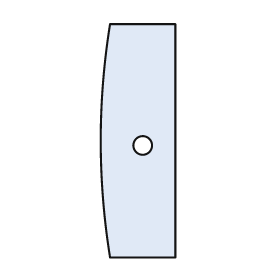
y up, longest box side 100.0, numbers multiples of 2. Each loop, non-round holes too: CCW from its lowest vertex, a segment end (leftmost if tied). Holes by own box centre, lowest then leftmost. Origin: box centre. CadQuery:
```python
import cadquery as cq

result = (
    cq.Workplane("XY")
    .moveTo(-12.0, -50.0)
    .lineTo(16.0, -50.0)
    .lineTo(16.0, 50.0)
    .lineTo(-12.0, 50.0)
    .threePointArc((-16.0, 0.0), (-12.0, -50.0))
    .close()
    .moveTo(2.0, -2.0)
    .circle(4.0)
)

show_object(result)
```